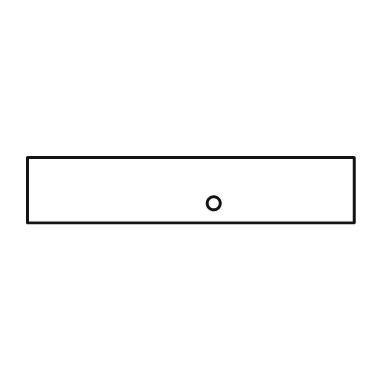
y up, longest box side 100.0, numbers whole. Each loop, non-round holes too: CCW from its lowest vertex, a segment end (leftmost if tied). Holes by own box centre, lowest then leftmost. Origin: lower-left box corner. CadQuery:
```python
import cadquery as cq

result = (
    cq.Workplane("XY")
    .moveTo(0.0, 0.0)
    .lineTo(100.0, 0.0)
    .lineTo(100.0, 20.0)
    .lineTo(0.0, 20.0)
    .close()
    .moveTo(57.0, 6.0)
    .circle(2.0)
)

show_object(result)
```